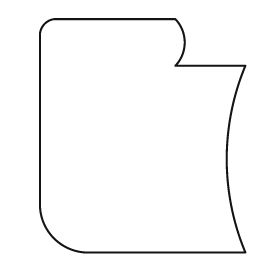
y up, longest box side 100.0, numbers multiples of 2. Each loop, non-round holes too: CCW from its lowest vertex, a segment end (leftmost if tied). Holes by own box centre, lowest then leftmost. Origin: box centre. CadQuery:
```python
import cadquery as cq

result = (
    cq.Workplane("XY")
    .moveTo(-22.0, -50.0)
    .lineTo(44.0, -50.0)
    .threePointArc((36.0, -10.0), (44.0, 30.0))
    .lineTo(14.0, 30.0)
    .threePointArc((18.0, 40.0), (14.0, 50.0))
    .lineTo(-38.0, 50.0)
    .threePointArc((-42.0, 48.0), (-44.0, 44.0))
    .lineTo(-44.0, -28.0)
    .threePointArc((-38.0, -44.0), (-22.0, -50.0))
    .close()
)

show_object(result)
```